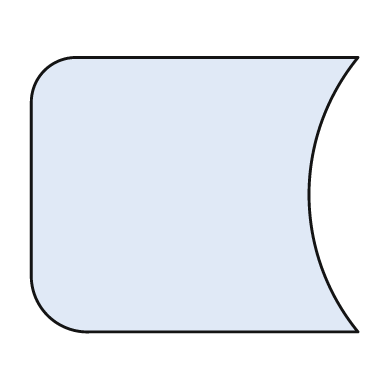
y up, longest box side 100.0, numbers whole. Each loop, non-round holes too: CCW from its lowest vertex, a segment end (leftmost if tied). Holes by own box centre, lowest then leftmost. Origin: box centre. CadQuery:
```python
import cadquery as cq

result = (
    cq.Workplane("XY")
    .moveTo(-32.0, -42.0)
    .lineTo(50.0, -42.0)
    .threePointArc((35.0, 0.0), (50.0, 42.0))
    .lineTo(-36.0, 42.0)
    .threePointArc((-46.0, 38.0), (-50.0, 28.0))
    .lineTo(-50.0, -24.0)
    .threePointArc((-45.0, -37.0), (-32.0, -42.0))
    .close()
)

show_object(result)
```